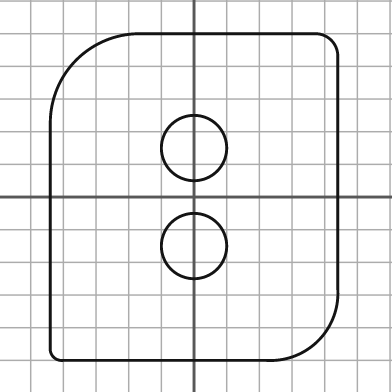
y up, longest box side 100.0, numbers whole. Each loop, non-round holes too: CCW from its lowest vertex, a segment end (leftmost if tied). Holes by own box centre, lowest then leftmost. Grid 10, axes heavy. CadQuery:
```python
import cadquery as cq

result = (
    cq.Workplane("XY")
    .moveTo(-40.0, -50.0)
    .lineTo(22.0, -50.0)
    .threePointArc((38.0, -44.0), (44.0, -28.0))
    .lineTo(44.0, 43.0)
    .threePointArc((42.0, 48.0), (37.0, 50.0))
    .lineTo(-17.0, 50.0)
    .threePointArc((-36.0, 42.0), (-44.0, 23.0))
    .lineTo(-44.0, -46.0)
    .threePointArc((-43.0, -49.0), (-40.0, -50.0))
    .close()
    .moveTo(0.0, -15.0)
    .circle(10.0)
    .moveTo(0.0, 15.0)
    .circle(10.0)
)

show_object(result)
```